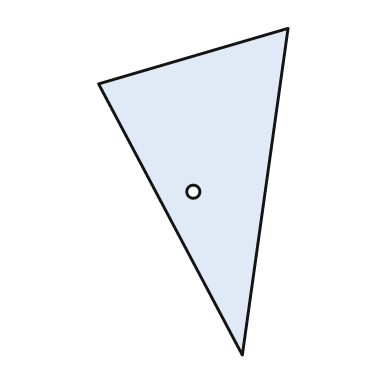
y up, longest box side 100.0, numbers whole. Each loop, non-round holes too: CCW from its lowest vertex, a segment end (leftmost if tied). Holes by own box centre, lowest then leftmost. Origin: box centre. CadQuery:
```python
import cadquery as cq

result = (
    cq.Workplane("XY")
    .moveTo(15.0, -50.0)
    .lineTo(29.0, 50.0)
    .lineTo(-29.0, 33.0)
    .close()
    .moveTo(0.0, 0.0)
    .circle(2.0)
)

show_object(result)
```